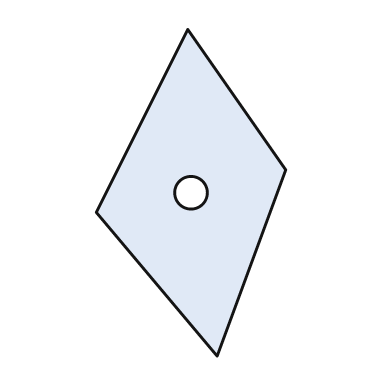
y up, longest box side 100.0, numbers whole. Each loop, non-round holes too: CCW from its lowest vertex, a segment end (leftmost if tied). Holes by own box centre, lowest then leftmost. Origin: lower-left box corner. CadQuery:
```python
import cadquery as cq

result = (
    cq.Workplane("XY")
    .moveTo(37.0, 0.0)
    .lineTo(58.0, 57.0)
    .lineTo(28.0, 100.0)
    .lineTo(0.0, 44.0)
    .close()
    .moveTo(29.0, 50.0)
    .circle(5.0)
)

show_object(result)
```